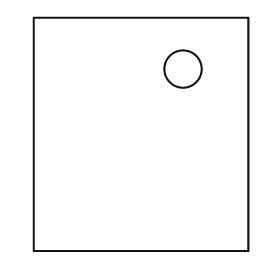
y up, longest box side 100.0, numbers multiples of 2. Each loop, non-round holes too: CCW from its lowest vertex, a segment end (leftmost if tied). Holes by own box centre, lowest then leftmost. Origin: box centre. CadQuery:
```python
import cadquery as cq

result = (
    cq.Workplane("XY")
    .moveTo(-46.0, -50.0)
    .lineTo(46.0, -50.0)
    .lineTo(46.0, 50.0)
    .lineTo(-46.0, 50.0)
    .close()
    .moveTo(18.0, 28.0)
    .circle(8.0)
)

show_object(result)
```